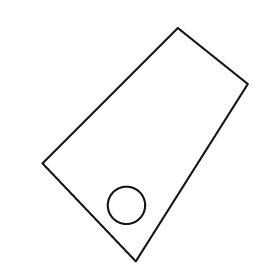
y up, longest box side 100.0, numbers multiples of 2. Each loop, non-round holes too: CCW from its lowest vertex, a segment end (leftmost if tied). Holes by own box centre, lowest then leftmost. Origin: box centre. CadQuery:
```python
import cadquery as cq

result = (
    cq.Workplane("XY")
    .moveTo(-4.0, -50.0)
    .lineTo(44.0, 26.0)
    .lineTo(14.0, 50.0)
    .lineTo(-44.0, -8.0)
    .close()
    .moveTo(-8.0, -26.0)
    .circle(8.0)
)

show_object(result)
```